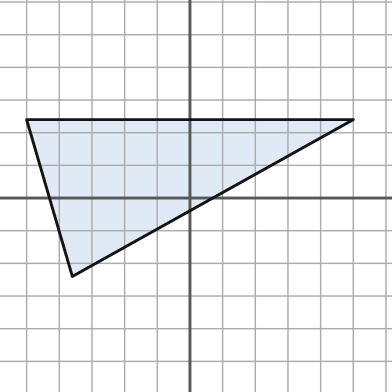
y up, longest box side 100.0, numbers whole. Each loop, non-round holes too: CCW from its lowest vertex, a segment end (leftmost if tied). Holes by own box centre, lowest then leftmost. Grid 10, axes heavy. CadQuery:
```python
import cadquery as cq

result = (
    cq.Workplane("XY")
    .moveTo(-36.0, -24.0)
    .lineTo(50.0, 24.0)
    .lineTo(-50.0, 24.0)
    .close()
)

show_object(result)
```